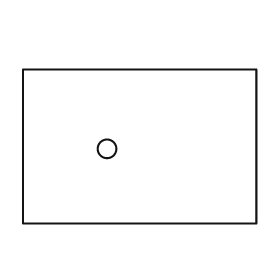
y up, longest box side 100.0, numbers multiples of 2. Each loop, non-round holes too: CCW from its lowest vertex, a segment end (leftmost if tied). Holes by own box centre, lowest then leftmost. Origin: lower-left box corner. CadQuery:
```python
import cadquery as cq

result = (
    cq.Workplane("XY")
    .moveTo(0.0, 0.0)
    .lineTo(100.0, 0.0)
    .lineTo(100.0, 66.0)
    .lineTo(0.0, 66.0)
    .close()
    .moveTo(36.0, 32.0)
    .circle(4.0)
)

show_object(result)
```